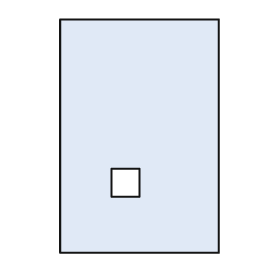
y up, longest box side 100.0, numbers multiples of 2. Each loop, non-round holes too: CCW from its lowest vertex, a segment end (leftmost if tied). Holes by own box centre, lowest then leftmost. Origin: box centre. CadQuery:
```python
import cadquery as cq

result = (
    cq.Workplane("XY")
    .moveTo(-34.0, -50.0)
    .lineTo(34.0, -50.0)
    .lineTo(34.0, 50.0)
    .lineTo(-34.0, 50.0)
    .close()
    .moveTo(-12.0, -26.0)
    .lineTo(0.0, -26.0)
    .lineTo(0.0, -14.0)
    .lineTo(-12.0, -14.0)
    .close()
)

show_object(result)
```